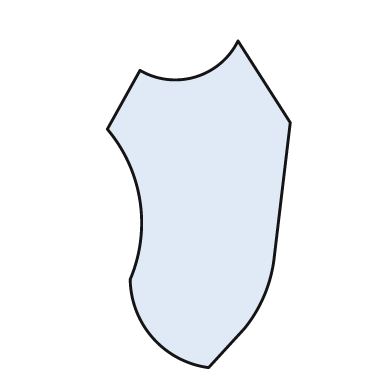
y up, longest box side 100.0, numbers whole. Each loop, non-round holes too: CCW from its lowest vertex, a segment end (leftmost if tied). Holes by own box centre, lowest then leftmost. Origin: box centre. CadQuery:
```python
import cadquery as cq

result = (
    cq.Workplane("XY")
    .moveTo(3.0, -50.0)
    .lineTo(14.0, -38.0)
    .threePointArc((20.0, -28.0), (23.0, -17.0))
    .lineTo(28.0, 25.0)
    .lineTo(12.0, 50.0)
    .threePointArc((-1.0, 39.0), (-18.0, 41.0))
    .lineTo(-28.0, 23.0)
    .threePointArc((-18.0, 1.0), (-21.0, -23.0))
    .threePointArc((-14.0, -41.0), (3.0, -50.0))
    .close()
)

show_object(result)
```